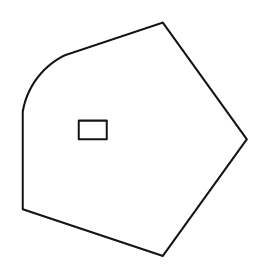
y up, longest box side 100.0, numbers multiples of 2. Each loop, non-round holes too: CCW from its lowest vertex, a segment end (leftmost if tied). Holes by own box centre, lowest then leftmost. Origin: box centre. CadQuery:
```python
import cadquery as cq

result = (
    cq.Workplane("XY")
    .moveTo(12.0, -50.0)
    .lineTo(48.0, 0.0)
    .lineTo(12.0, 50.0)
    .lineTo(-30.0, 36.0)
    .threePointArc((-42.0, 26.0), (-48.0, 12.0))
    .lineTo(-48.0, -30.0)
    .close()
    .moveTo(-24.0, 0.0)
    .lineTo(-12.0, 0.0)
    .lineTo(-12.0, 8.0)
    .lineTo(-24.0, 8.0)
    .close()
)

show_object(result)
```